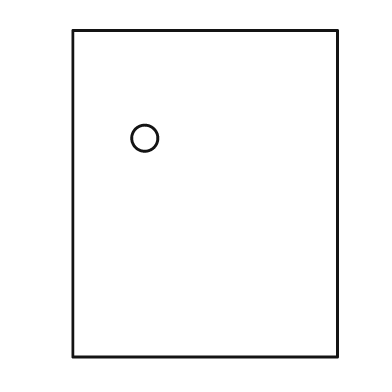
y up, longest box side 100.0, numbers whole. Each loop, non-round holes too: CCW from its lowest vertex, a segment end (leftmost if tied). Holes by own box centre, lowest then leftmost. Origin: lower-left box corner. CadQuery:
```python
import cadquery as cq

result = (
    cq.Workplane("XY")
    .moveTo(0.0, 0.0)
    .lineTo(81.0, 0.0)
    .lineTo(81.0, 100.0)
    .lineTo(0.0, 100.0)
    .close()
    .moveTo(22.0, 67.0)
    .circle(4.0)
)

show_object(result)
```